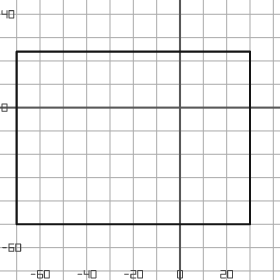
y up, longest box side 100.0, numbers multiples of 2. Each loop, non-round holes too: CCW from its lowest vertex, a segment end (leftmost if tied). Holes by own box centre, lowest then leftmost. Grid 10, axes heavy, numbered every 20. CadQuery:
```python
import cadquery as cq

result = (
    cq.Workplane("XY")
    .moveTo(-70.0, -50.0)
    .lineTo(30.0, -50.0)
    .lineTo(30.0, 24.0)
    .lineTo(-70.0, 24.0)
    .close()
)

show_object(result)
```